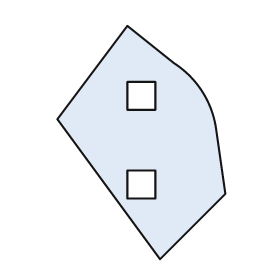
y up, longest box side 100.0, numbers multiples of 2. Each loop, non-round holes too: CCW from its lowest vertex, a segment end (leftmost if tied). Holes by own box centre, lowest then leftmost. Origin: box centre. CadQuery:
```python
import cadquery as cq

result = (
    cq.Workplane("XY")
    .moveTo(8.0, -50.0)
    .lineTo(36.0, -22.0)
    .lineTo(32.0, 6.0)
    .threePointArc((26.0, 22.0), (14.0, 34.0))
    .lineTo(-6.0, 50.0)
    .lineTo(-36.0, 10.0)
    .close()
    .moveTo(-6.0, -24.0)
    .lineTo(6.0, -24.0)
    .lineTo(6.0, -12.0)
    .lineTo(-6.0, -12.0)
    .close()
    .moveTo(-6.0, 14.0)
    .lineTo(6.0, 14.0)
    .lineTo(6.0, 26.0)
    .lineTo(-6.0, 26.0)
    .close()
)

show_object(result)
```